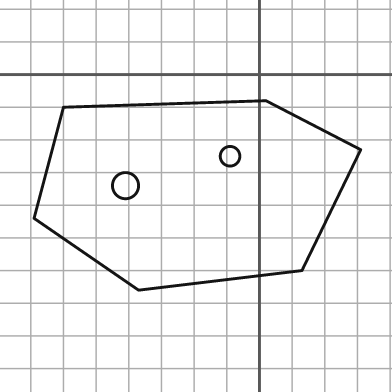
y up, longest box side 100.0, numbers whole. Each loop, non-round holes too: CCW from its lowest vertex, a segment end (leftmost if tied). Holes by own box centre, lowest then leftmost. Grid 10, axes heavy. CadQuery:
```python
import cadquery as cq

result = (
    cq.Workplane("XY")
    .moveTo(-37.0, -66.0)
    .lineTo(13.0, -60.0)
    .lineTo(31.0, -23.0)
    .lineTo(2.0, -8.0)
    .lineTo(-60.0, -10.0)
    .lineTo(-69.0, -44.0)
    .close()
    .moveTo(-41.0, -34.0)
    .circle(4.0)
    .moveTo(-9.0, -25.0)
    .circle(3.0)
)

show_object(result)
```